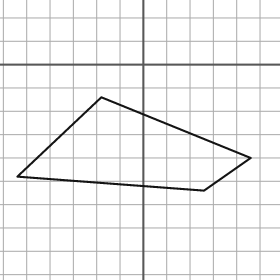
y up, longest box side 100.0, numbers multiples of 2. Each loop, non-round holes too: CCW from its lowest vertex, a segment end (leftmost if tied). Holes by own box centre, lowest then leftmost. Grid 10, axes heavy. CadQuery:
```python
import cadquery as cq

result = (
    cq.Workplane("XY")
    .moveTo(26.0, -54.0)
    .lineTo(46.0, -40.0)
    .lineTo(-18.0, -14.0)
    .lineTo(-54.0, -48.0)
    .close()
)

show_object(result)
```